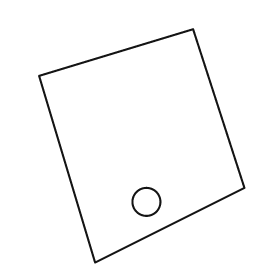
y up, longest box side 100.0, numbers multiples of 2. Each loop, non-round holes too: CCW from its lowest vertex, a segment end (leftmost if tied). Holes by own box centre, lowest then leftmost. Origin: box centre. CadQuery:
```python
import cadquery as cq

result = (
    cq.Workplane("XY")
    .moveTo(-20.0, -50.0)
    .lineTo(44.0, -18.0)
    .lineTo(22.0, 50.0)
    .lineTo(-44.0, 30.0)
    .close()
    .moveTo(2.0, -24.0)
    .circle(6.0)
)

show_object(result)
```